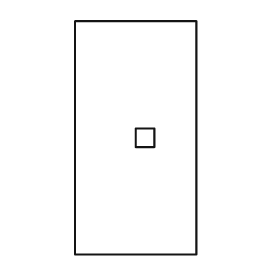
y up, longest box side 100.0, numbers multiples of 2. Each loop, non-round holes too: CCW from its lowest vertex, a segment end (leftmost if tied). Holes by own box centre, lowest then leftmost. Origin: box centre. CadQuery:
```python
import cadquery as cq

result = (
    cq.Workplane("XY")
    .moveTo(-26.0, -50.0)
    .lineTo(26.0, -50.0)
    .lineTo(26.0, 50.0)
    .lineTo(-26.0, 50.0)
    .close()
    .moveTo(0.0, -4.0)
    .lineTo(8.0, -4.0)
    .lineTo(8.0, 4.0)
    .lineTo(0.0, 4.0)
    .close()
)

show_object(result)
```